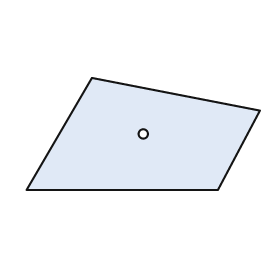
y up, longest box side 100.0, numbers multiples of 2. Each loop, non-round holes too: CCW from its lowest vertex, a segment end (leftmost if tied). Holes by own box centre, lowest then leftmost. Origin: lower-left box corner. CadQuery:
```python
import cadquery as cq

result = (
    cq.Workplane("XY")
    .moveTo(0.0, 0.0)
    .lineTo(82.0, 0.0)
    .lineTo(100.0, 34.0)
    .lineTo(28.0, 48.0)
    .close()
    .moveTo(50.0, 24.0)
    .circle(2.0)
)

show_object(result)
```